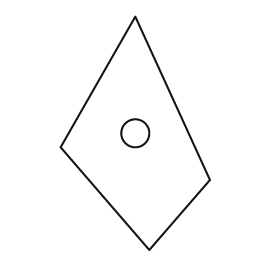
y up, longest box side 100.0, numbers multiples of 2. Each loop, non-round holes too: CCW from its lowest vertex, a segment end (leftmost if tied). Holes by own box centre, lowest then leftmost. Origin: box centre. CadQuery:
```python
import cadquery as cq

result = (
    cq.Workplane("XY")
    .moveTo(6.0, -50.0)
    .lineTo(32.0, -20.0)
    .lineTo(0.0, 50.0)
    .lineTo(-32.0, -6.0)
    .close()
    .moveTo(0.0, 0.0)
    .circle(6.0)
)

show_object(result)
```